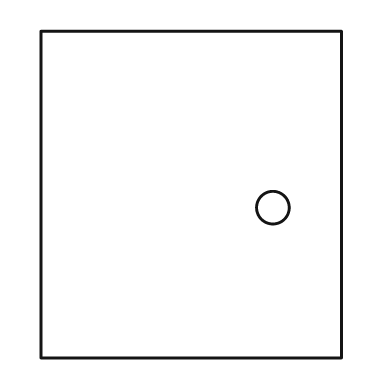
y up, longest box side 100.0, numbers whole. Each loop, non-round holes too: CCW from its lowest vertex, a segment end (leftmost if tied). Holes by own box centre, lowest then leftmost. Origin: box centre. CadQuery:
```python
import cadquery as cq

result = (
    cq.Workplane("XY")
    .moveTo(-46.0, -50.0)
    .lineTo(46.0, -50.0)
    .lineTo(46.0, 50.0)
    .lineTo(-46.0, 50.0)
    .close()
    .moveTo(25.0, -4.0)
    .circle(5.0)
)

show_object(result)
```